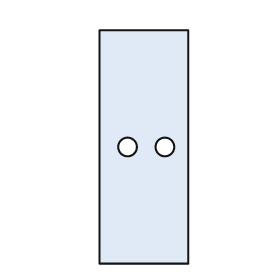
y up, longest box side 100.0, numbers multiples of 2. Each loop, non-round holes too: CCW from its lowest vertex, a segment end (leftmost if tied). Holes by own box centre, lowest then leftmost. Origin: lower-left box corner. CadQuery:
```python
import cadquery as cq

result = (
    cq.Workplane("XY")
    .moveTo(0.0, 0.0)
    .lineTo(38.0, 0.0)
    .lineTo(38.0, 100.0)
    .lineTo(0.0, 100.0)
    .close()
    .moveTo(12.0, 50.0)
    .circle(4.0)
    .moveTo(28.0, 50.0)
    .circle(4.0)
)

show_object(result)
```